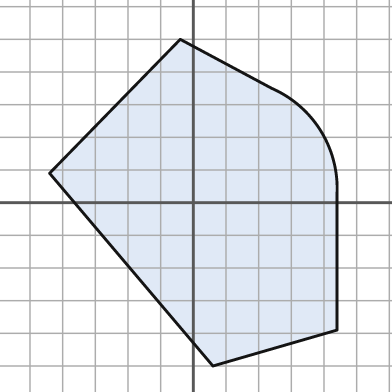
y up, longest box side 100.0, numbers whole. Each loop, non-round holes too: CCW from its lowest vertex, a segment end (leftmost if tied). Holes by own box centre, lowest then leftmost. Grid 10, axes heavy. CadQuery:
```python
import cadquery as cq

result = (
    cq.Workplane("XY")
    .moveTo(6.0, -50.0)
    .lineTo(44.0, -39.0)
    .lineTo(44.0, 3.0)
    .threePointArc((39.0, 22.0), (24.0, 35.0))
    .lineTo(-4.0, 50.0)
    .lineTo(-44.0, 9.0)
    .close()
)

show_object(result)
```